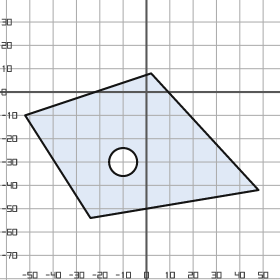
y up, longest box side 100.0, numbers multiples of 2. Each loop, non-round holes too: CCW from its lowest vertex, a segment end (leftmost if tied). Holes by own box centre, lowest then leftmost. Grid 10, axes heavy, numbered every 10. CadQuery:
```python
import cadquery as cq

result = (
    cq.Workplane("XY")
    .moveTo(-24.0, -54.0)
    .lineTo(48.0, -42.0)
    .lineTo(2.0, 8.0)
    .lineTo(-52.0, -10.0)
    .close()
    .moveTo(-10.0, -30.0)
    .circle(6.0)
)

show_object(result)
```